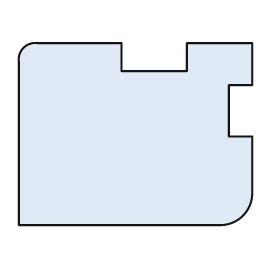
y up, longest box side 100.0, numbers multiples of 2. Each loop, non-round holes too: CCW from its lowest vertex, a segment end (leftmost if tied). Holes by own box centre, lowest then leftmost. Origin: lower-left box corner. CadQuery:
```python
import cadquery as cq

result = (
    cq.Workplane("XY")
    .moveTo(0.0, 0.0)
    .lineTo(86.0, 0.0)
    .threePointArc((96.0, 4.0), (100.0, 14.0))
    .lineTo(100.0, 38.0)
    .lineTo(90.0, 38.0)
    .lineTo(90.0, 60.0)
    .lineTo(100.0, 60.0)
    .lineTo(100.0, 78.0)
    .lineTo(72.0, 78.0)
    .lineTo(72.0, 66.0)
    .lineTo(44.0, 66.0)
    .lineTo(44.0, 78.0)
    .lineTo(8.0, 78.0)
    .threePointArc((2.0, 76.0), (0.0, 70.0))
    .close()
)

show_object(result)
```